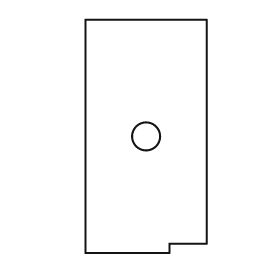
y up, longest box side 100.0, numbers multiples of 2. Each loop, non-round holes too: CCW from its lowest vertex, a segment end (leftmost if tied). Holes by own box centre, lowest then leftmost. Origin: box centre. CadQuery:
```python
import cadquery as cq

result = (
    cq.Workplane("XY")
    .moveTo(-26.0, -50.0)
    .lineTo(10.0, -50.0)
    .lineTo(10.0, -46.0)
    .lineTo(26.0, -46.0)
    .lineTo(26.0, 50.0)
    .lineTo(-26.0, 50.0)
    .close()
    .moveTo(0.0, 0.0)
    .circle(6.0)
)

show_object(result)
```